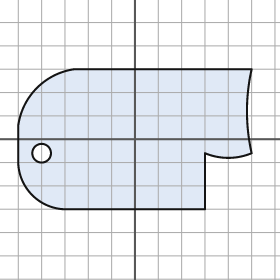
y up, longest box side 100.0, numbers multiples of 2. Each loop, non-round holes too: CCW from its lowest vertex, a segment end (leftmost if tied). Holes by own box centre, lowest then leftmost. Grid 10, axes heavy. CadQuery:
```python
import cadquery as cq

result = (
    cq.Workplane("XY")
    .moveTo(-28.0, -30.0)
    .lineTo(30.0, -30.0)
    .lineTo(30.0, -6.0)
    .threePointArc((40.0, -8.0), (50.0, -6.0))
    .threePointArc((48.0, 12.0), (50.0, 30.0))
    .lineTo(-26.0, 30.0)
    .threePointArc((-42.0, 22.0), (-50.0, 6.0))
    .lineTo(-50.0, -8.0)
    .threePointArc((-44.0, -24.0), (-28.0, -30.0))
    .close()
    .moveTo(-40.0, -6.0)
    .circle(4.0)
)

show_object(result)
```